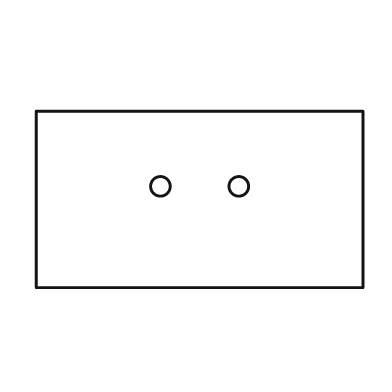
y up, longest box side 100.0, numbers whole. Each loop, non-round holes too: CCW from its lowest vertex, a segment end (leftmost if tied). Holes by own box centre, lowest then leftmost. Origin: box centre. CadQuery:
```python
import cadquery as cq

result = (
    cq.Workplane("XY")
    .moveTo(-50.0, -27.0)
    .lineTo(50.0, -27.0)
    .lineTo(50.0, 27.0)
    .lineTo(-50.0, 27.0)
    .close()
    .moveTo(-12.0, 4.0)
    .circle(3.0)
    .moveTo(12.0, 4.0)
    .circle(3.0)
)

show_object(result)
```